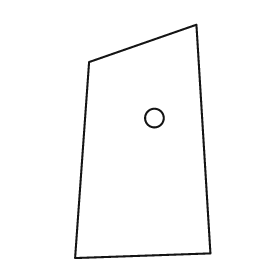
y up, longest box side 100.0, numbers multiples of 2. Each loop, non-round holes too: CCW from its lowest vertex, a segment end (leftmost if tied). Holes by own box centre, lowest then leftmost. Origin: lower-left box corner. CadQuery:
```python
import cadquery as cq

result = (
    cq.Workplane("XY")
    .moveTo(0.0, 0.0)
    .lineTo(58.0, 2.0)
    .lineTo(52.0, 100.0)
    .lineTo(6.0, 84.0)
    .close()
    .moveTo(34.0, 60.0)
    .circle(4.0)
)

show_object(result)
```